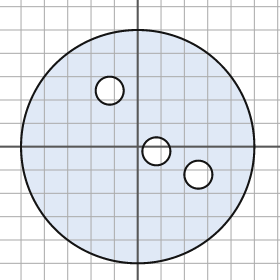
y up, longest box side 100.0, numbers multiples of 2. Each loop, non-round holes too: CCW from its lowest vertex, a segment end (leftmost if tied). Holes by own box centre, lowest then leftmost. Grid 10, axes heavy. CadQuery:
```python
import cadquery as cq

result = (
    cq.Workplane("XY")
    .moveTo(0.0, 0.0)
    .circle(50.0)
    .moveTo(26.0, -12.0)
    .circle(6.0)
    .moveTo(8.0, -2.0)
    .circle(6.0)
    .moveTo(-12.0, 24.0)
    .circle(6.0)
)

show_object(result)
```